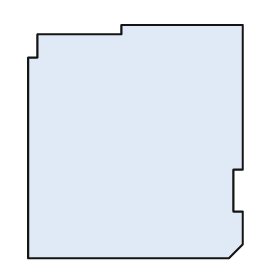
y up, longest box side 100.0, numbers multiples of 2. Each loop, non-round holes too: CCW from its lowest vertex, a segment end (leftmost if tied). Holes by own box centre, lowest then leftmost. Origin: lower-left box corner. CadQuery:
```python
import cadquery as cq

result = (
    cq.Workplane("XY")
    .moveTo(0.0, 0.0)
    .lineTo(86.0, 0.0)
    .lineTo(92.0, 6.0)
    .lineTo(92.0, 20.0)
    .lineTo(88.0, 20.0)
    .lineTo(88.0, 38.0)
    .lineTo(92.0, 38.0)
    .lineTo(92.0, 100.0)
    .lineTo(40.0, 100.0)
    .lineTo(40.0, 96.0)
    .lineTo(4.0, 96.0)
    .lineTo(4.0, 86.0)
    .lineTo(0.0, 86.0)
    .close()
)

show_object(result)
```